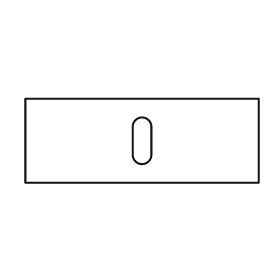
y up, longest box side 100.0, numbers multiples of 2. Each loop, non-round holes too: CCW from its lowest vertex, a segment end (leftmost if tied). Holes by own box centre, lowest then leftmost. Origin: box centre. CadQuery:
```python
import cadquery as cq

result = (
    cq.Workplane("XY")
    .moveTo(-50.0, -18.0)
    .lineTo(50.0, -18.0)
    .lineTo(50.0, 18.0)
    .lineTo(-50.0, 18.0)
    .close()
    .moveTo(-4.0, -6.0)
    .threePointArc((0.0, -10.0), (4.0, -6.0))
    .lineTo(4.0, 6.0)
    .threePointArc((0.0, 10.0), (-4.0, 6.0))
    .close()
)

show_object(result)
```